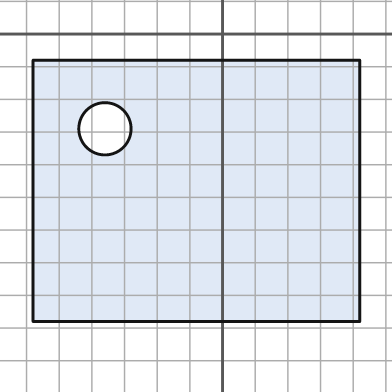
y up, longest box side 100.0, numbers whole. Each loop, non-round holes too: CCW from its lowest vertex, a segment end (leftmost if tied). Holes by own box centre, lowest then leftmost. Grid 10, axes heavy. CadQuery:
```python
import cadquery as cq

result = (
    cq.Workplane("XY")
    .moveTo(-58.0, -88.0)
    .lineTo(42.0, -88.0)
    .lineTo(42.0, -8.0)
    .lineTo(-58.0, -8.0)
    .close()
    .moveTo(-36.0, -29.0)
    .circle(8.0)
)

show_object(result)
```